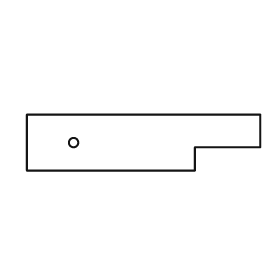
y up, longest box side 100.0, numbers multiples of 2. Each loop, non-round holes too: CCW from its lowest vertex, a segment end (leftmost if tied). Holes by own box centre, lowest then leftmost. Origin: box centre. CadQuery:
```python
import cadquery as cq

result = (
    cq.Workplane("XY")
    .moveTo(-50.0, -12.0)
    .lineTo(22.0, -12.0)
    .lineTo(22.0, -2.0)
    .lineTo(50.0, -2.0)
    .lineTo(50.0, 12.0)
    .lineTo(-50.0, 12.0)
    .close()
    .moveTo(-30.0, 0.0)
    .circle(2.0)
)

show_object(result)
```